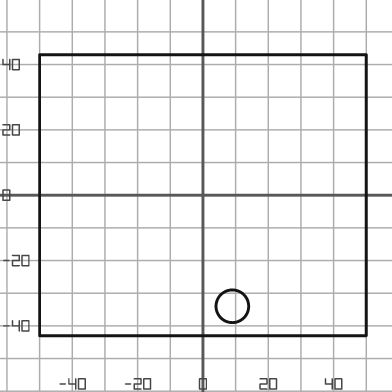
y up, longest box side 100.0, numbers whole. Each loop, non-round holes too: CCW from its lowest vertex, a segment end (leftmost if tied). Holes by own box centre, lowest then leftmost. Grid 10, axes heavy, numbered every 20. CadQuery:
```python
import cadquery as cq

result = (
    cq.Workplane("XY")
    .moveTo(-50.0, -43.0)
    .lineTo(50.0, -43.0)
    .lineTo(50.0, 43.0)
    .lineTo(-50.0, 43.0)
    .close()
    .moveTo(9.0, -34.0)
    .circle(5.0)
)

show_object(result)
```